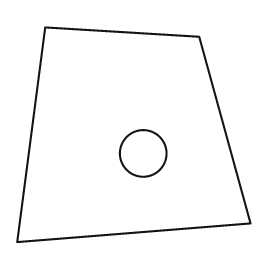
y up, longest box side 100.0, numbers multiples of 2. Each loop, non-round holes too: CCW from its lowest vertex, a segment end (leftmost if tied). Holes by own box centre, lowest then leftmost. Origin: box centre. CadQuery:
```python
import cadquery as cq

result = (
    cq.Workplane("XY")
    .moveTo(-50.0, -46.0)
    .lineTo(50.0, -38.0)
    .lineTo(28.0, 42.0)
    .lineTo(-38.0, 46.0)
    .close()
    .moveTo(4.0, -8.0)
    .circle(10.0)
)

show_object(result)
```